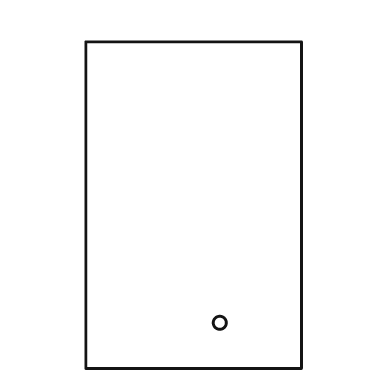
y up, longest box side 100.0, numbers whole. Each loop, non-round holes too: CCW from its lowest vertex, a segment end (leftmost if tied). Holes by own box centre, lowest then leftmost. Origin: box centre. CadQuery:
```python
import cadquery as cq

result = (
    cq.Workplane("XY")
    .moveTo(-33.0, -50.0)
    .lineTo(33.0, -50.0)
    .lineTo(33.0, 50.0)
    .lineTo(-33.0, 50.0)
    .close()
    .moveTo(8.0, -36.0)
    .circle(2.0)
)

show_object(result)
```